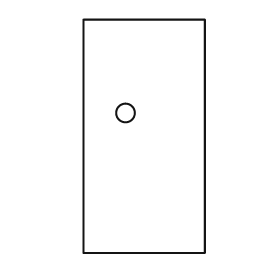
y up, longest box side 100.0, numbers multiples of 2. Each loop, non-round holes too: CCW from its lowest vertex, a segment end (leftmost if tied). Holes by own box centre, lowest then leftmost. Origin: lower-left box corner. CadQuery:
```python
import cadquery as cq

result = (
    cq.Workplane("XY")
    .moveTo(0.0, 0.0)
    .lineTo(52.0, 0.0)
    .lineTo(52.0, 100.0)
    .lineTo(0.0, 100.0)
    .close()
    .moveTo(18.0, 60.0)
    .circle(4.0)
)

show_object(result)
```